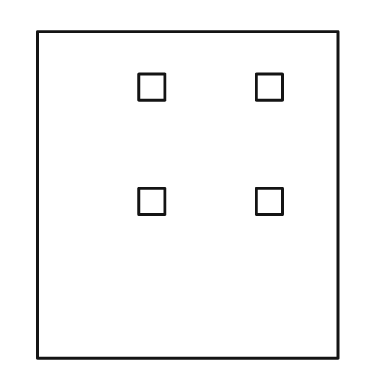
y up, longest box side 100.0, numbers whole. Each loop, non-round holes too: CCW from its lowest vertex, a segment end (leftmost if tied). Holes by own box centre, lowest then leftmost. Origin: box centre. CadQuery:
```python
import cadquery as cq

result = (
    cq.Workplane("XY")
    .moveTo(-46.0, -50.0)
    .lineTo(46.0, -50.0)
    .lineTo(46.0, 50.0)
    .lineTo(-46.0, 50.0)
    .close()
    .moveTo(-15.0, -6.0)
    .lineTo(-7.0, -6.0)
    .lineTo(-7.0, 2.0)
    .lineTo(-15.0, 2.0)
    .close()
    .moveTo(21.0, -6.0)
    .lineTo(29.0, -6.0)
    .lineTo(29.0, 2.0)
    .lineTo(21.0, 2.0)
    .close()
    .moveTo(-15.0, 29.0)
    .lineTo(-7.0, 29.0)
    .lineTo(-7.0, 37.0)
    .lineTo(-15.0, 37.0)
    .close()
    .moveTo(21.0, 29.0)
    .lineTo(29.0, 29.0)
    .lineTo(29.0, 37.0)
    .lineTo(21.0, 37.0)
    .close()
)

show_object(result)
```